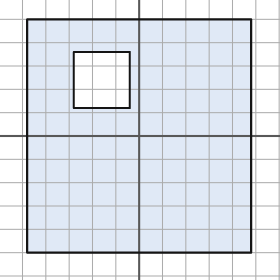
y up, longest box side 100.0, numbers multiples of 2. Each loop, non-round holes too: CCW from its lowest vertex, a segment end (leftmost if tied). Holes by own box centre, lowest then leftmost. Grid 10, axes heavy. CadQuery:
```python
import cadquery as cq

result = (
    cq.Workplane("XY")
    .moveTo(-48.0, -50.0)
    .lineTo(48.0, -50.0)
    .lineTo(48.0, 50.0)
    .lineTo(-48.0, 50.0)
    .close()
    .moveTo(-28.0, 12.0)
    .lineTo(-4.0, 12.0)
    .lineTo(-4.0, 36.0)
    .lineTo(-28.0, 36.0)
    .close()
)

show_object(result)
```